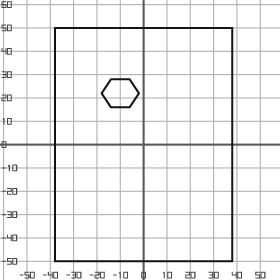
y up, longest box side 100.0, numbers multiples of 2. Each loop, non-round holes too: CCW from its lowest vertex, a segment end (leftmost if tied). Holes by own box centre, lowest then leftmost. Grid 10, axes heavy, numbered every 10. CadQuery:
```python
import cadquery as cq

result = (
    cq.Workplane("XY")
    .moveTo(-38.0, -50.0)
    .lineTo(38.0, -50.0)
    .lineTo(38.0, 50.0)
    .lineTo(-38.0, 50.0)
    .close()
    .moveTo(-14.0, 16.0)
    .lineTo(-6.0, 16.0)
    .lineTo(-2.0, 22.0)
    .lineTo(-6.0, 28.0)
    .lineTo(-14.0, 28.0)
    .lineTo(-18.0, 22.0)
    .close()
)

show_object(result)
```